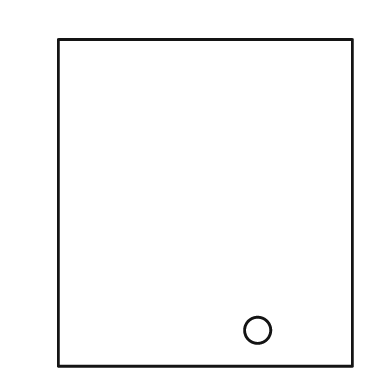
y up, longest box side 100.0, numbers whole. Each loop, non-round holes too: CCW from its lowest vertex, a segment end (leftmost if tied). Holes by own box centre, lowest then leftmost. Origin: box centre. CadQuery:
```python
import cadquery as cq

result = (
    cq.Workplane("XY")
    .moveTo(-45.0, -50.0)
    .lineTo(45.0, -50.0)
    .lineTo(45.0, 50.0)
    .lineTo(-45.0, 50.0)
    .close()
    .moveTo(16.0, -39.0)
    .circle(4.0)
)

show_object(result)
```